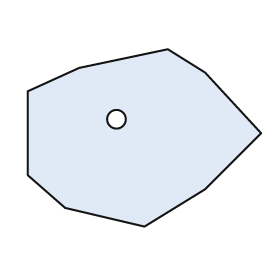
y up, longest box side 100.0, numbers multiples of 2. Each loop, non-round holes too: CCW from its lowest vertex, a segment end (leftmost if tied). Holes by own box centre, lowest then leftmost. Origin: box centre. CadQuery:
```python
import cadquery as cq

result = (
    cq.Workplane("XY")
    .moveTo(0.0, -38.0)
    .lineTo(26.0, -22.0)
    .lineTo(50.0, 2.0)
    .lineTo(26.0, 28.0)
    .lineTo(10.0, 38.0)
    .lineTo(-28.0, 30.0)
    .lineTo(-50.0, 20.0)
    .lineTo(-50.0, -16.0)
    .lineTo(-34.0, -30.0)
    .close()
    .moveTo(-12.0, 8.0)
    .circle(4.0)
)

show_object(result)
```